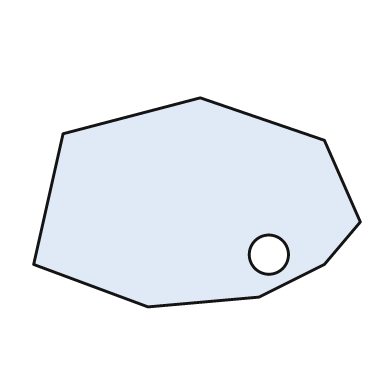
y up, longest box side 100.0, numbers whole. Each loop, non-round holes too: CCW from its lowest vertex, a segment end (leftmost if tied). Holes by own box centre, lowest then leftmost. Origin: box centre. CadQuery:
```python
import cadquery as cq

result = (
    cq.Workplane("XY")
    .moveTo(-15.0, -32.0)
    .lineTo(19.0, -29.0)
    .lineTo(39.0, -19.0)
    .lineTo(50.0, -6.0)
    .lineTo(39.0, 19.0)
    .lineTo(1.0, 32.0)
    .lineTo(-41.0, 21.0)
    .lineTo(-50.0, -19.0)
    .close()
    .moveTo(22.0, -16.0)
    .circle(6.0)
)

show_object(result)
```